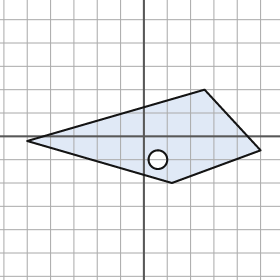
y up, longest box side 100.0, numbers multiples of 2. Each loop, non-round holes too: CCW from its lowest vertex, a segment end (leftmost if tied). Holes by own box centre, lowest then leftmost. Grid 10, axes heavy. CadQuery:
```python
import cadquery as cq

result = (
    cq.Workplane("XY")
    .moveTo(12.0, -20.0)
    .lineTo(50.0, -6.0)
    .lineTo(26.0, 20.0)
    .lineTo(-50.0, -2.0)
    .close()
    .moveTo(6.0, -10.0)
    .circle(4.0)
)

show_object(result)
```